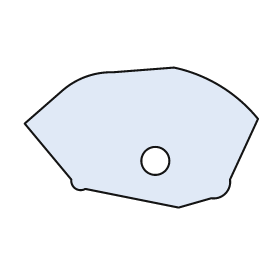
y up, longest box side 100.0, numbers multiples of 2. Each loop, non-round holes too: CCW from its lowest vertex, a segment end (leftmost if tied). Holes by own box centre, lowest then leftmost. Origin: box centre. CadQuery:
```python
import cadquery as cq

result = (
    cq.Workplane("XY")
    .moveTo(16.0, -30.0)
    .lineTo(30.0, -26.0)
    .threePointArc((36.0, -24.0), (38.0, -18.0))
    .lineTo(50.0, 8.0)
    .threePointArc((34.0, 22.0), (14.0, 30.0))
    .lineTo(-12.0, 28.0)
    .threePointArc((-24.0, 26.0), (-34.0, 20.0))
    .lineTo(-50.0, 6.0)
    .lineTo(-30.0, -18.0)
    .threePointArc((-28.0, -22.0), (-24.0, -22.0))
    .close()
    .moveTo(6.0, -10.0)
    .circle(6.0)
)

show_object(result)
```